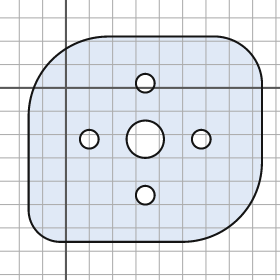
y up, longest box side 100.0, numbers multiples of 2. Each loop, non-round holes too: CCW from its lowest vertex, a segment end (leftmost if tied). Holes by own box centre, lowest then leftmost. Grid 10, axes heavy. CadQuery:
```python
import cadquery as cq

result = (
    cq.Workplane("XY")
    .moveTo(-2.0, -66.0)
    .lineTo(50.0, -66.0)
    .threePointArc((74.0, -56.0), (84.0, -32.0))
    .lineTo(84.0, 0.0)
    .threePointArc((78.0, 16.0), (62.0, 22.0))
    .lineTo(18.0, 22.0)
    .threePointArc((-6.0, 12.0), (-16.0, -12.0))
    .lineTo(-16.0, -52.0)
    .threePointArc((-12.0, -62.0), (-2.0, -66.0))
    .close()
    .moveTo(34.0, -46.0)
    .circle(4.0)
    .moveTo(10.0, -22.0)
    .circle(4.0)
    .moveTo(34.0, -22.0)
    .circle(8.0)
    .moveTo(58.0, -22.0)
    .circle(4.0)
    .moveTo(34.0, 2.0)
    .circle(4.0)
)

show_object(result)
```